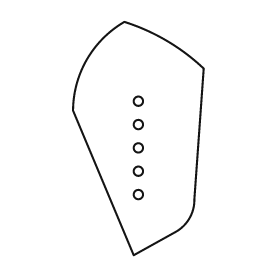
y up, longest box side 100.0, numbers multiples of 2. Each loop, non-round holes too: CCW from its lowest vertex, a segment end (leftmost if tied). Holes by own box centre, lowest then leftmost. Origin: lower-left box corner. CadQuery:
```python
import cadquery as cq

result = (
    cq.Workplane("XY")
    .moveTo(26.0, 0.0)
    .lineTo(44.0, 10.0)
    .threePointArc((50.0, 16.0), (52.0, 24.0))
    .lineTo(56.0, 80.0)
    .threePointArc((40.0, 92.0), (22.0, 100.0))
    .threePointArc((6.0, 84.0), (0.0, 62.0))
    .close()
    .moveTo(28.0, 26.0)
    .circle(2.0)
    .moveTo(28.0, 36.0)
    .circle(2.0)
    .moveTo(28.0, 46.0)
    .circle(2.0)
    .moveTo(28.0, 56.0)
    .circle(2.0)
    .moveTo(28.0, 66.0)
    .circle(2.0)
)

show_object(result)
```